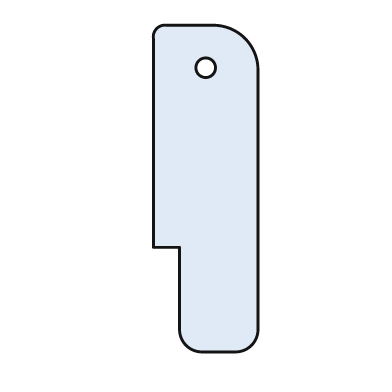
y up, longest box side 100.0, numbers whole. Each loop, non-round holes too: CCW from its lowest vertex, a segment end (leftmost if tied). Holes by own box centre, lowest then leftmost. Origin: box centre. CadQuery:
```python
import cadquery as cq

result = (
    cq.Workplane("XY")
    .moveTo(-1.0, -50.0)
    .lineTo(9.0, -50.0)
    .threePointArc((14.0, -48.0), (16.0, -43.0))
    .lineTo(16.0, 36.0)
    .threePointArc((12.0, 46.0), (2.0, 50.0))
    .lineTo(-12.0, 50.0)
    .threePointArc((-15.0, 49.0), (-16.0, 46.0))
    .lineTo(-16.0, -18.0)
    .lineTo(-8.0, -18.0)
    .lineTo(-8.0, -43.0)
    .threePointArc((-6.0, -48.0), (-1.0, -50.0))
    .close()
    .moveTo(0.0, 37.0)
    .circle(3.0)
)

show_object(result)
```